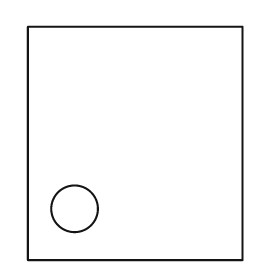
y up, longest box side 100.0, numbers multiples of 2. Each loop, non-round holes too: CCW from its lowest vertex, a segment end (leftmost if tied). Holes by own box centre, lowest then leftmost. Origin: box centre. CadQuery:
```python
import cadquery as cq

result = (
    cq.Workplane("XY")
    .moveTo(-46.0, -50.0)
    .lineTo(46.0, -50.0)
    .lineTo(46.0, 50.0)
    .lineTo(-46.0, 50.0)
    .close()
    .moveTo(-26.0, -28.0)
    .circle(10.0)
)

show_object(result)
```